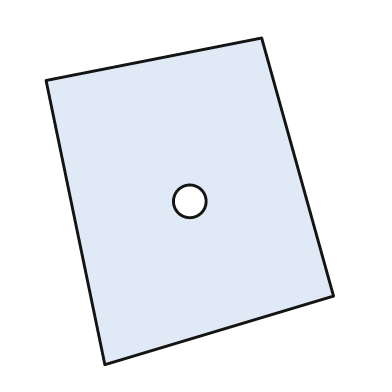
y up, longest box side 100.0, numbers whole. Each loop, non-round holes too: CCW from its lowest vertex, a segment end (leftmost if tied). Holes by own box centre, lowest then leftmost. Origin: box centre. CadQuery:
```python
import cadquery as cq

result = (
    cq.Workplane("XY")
    .moveTo(-26.0, -50.0)
    .lineTo(44.0, -29.0)
    .lineTo(22.0, 50.0)
    .lineTo(-44.0, 37.0)
    .close()
    .moveTo(0.0, 0.0)
    .circle(5.0)
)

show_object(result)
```